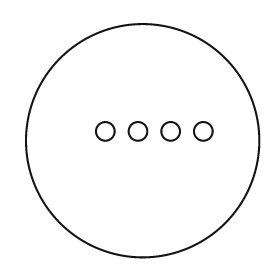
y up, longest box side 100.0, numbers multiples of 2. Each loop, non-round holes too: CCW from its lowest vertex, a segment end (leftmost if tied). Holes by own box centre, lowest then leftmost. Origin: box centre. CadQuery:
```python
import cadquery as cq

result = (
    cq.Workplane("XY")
    .moveTo(0.0, 0.0)
    .circle(50.0)
    .moveTo(-16.0, 4.0)
    .circle(4.0)
    .moveTo(-2.0, 4.0)
    .circle(4.0)
    .moveTo(12.0, 4.0)
    .circle(4.0)
    .moveTo(26.0, 4.0)
    .circle(4.0)
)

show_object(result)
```